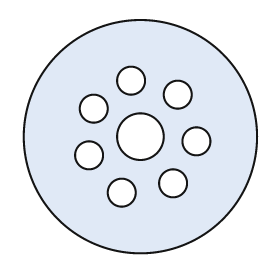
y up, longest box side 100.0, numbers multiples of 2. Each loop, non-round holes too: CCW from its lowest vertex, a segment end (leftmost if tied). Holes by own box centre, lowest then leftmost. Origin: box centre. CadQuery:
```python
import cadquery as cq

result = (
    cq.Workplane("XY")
    .moveTo(0.0, 0.0)
    .circle(50.0)
    .moveTo(-8.0, -24.0)
    .circle(6.0)
    .moveTo(14.0, -20.0)
    .circle(6.0)
    .moveTo(-22.0, -8.0)
    .circle(6.0)
    .moveTo(24.0, -2.0)
    .circle(6.0)
    .moveTo(0.0, 0.0)
    .circle(10.0)
    .moveTo(-20.0, 12.0)
    .circle(6.0)
    .moveTo(16.0, 18.0)
    .circle(6.0)
    .moveTo(-4.0, 24.0)
    .circle(6.0)
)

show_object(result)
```